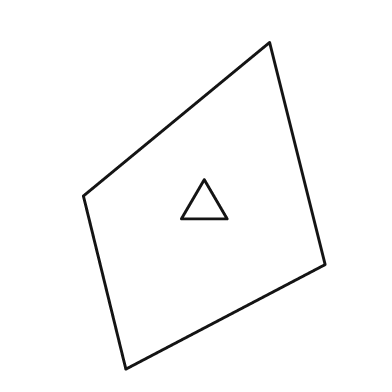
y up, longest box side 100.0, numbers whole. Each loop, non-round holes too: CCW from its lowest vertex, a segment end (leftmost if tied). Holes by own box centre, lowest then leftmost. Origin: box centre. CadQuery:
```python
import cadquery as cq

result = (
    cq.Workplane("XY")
    .moveTo(-24.0, -50.0)
    .lineTo(37.0, -18.0)
    .lineTo(20.0, 50.0)
    .lineTo(-37.0, 3.0)
    .close()
    .moveTo(-7.0, -4.0)
    .lineTo(7.0, -4.0)
    .lineTo(0.0, 8.0)
    .close()
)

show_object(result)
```